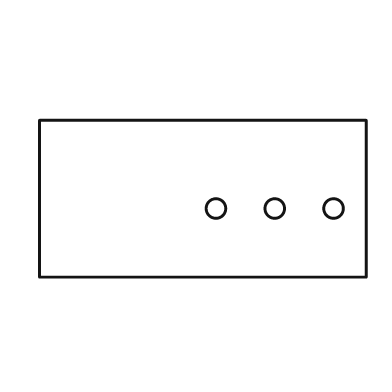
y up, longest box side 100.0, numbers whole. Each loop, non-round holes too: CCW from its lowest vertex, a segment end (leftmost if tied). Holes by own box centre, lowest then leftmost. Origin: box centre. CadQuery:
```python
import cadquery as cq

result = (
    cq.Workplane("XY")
    .moveTo(-50.0, -24.0)
    .lineTo(50.0, -24.0)
    .lineTo(50.0, 24.0)
    .lineTo(-50.0, 24.0)
    .close()
    .moveTo(4.0, -3.0)
    .circle(3.0)
    .moveTo(22.0, -3.0)
    .circle(3.0)
    .moveTo(40.0, -3.0)
    .circle(3.0)
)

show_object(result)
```